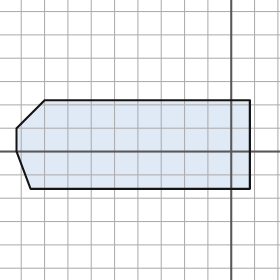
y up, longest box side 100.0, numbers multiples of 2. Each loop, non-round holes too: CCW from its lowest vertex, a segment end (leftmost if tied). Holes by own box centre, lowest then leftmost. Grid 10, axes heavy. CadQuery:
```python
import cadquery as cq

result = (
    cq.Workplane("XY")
    .moveTo(-86.0, -16.0)
    .lineTo(8.0, -16.0)
    .lineTo(8.0, 22.0)
    .lineTo(-80.0, 22.0)
    .lineTo(-92.0, 10.0)
    .lineTo(-92.0, 0.0)
    .close()
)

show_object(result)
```